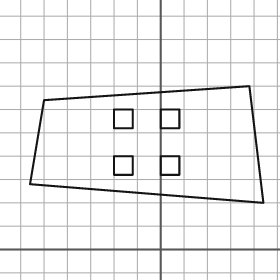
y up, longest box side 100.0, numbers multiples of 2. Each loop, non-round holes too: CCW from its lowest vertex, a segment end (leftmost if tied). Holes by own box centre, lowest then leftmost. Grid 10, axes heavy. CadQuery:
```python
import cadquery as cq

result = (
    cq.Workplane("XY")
    .moveTo(44.0, 20.0)
    .lineTo(38.0, 70.0)
    .lineTo(-50.0, 64.0)
    .lineTo(-56.0, 28.0)
    .close()
    .moveTo(-20.0, 32.0)
    .lineTo(-12.0, 32.0)
    .lineTo(-12.0, 40.0)
    .lineTo(-20.0, 40.0)
    .close()
    .moveTo(0.0, 32.0)
    .lineTo(8.0, 32.0)
    .lineTo(8.0, 40.0)
    .lineTo(0.0, 40.0)
    .close()
    .moveTo(-20.0, 52.0)
    .lineTo(-12.0, 52.0)
    .lineTo(-12.0, 60.0)
    .lineTo(-20.0, 60.0)
    .close()
    .moveTo(0.0, 52.0)
    .lineTo(8.0, 52.0)
    .lineTo(8.0, 60.0)
    .lineTo(0.0, 60.0)
    .close()
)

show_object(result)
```